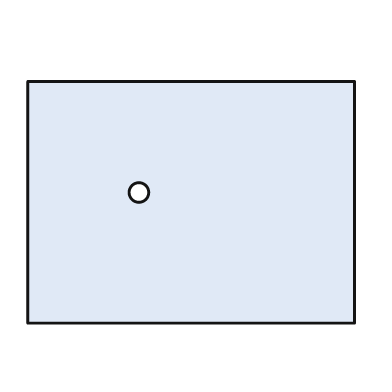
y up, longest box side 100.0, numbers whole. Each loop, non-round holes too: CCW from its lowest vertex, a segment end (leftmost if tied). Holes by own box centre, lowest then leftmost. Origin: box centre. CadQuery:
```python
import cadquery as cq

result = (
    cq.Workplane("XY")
    .moveTo(-50.0, -37.0)
    .lineTo(50.0, -37.0)
    .lineTo(50.0, 37.0)
    .lineTo(-50.0, 37.0)
    .close()
    .moveTo(-16.0, 3.0)
    .circle(3.0)
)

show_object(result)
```